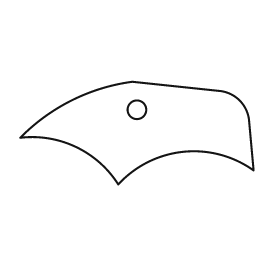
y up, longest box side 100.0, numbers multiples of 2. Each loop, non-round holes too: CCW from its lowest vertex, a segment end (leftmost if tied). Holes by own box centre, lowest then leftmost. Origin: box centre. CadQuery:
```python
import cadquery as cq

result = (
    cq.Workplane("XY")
    .moveTo(-8.0, -22.0)
    .threePointArc((20.0, -8.0), (50.0, -16.0))
    .lineTo(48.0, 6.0)
    .threePointArc((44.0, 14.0), (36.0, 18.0))
    .lineTo(-2.0, 22.0)
    .threePointArc((-28.0, 14.0), (-50.0, -2.0))
    .threePointArc((-26.0, -6.0), (-8.0, -22.0))
    .close()
    .moveTo(0.0, 10.0)
    .circle(4.0)
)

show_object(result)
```